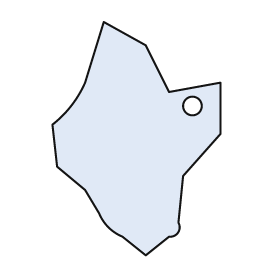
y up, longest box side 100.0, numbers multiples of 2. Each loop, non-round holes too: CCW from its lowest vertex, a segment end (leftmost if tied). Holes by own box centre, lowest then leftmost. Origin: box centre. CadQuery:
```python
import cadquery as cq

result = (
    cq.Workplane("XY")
    .moveTo(4.0, -50.0)
    .lineTo(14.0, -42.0)
    .threePointArc((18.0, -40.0), (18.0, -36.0))
    .lineTo(20.0, -16.0)
    .lineTo(36.0, 2.0)
    .lineTo(36.0, 24.0)
    .lineTo(14.0, 20.0)
    .lineTo(4.0, 40.0)
    .lineTo(-14.0, 50.0)
    .lineTo(-22.0, 24.0)
    .threePointArc((-28.0, 14.0), (-36.0, 6.0))
    .lineTo(-34.0, -12.0)
    .lineTo(-22.0, -22.0)
    .lineTo(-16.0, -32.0)
    .threePointArc((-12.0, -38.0), (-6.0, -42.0))
    .close()
    .moveTo(24.0, 14.0)
    .circle(4.0)
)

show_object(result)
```